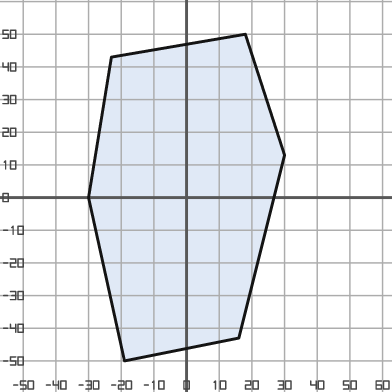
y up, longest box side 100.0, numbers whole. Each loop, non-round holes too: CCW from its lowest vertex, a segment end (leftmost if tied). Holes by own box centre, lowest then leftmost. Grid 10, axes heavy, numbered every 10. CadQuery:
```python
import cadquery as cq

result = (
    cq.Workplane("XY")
    .moveTo(-19.0, -50.0)
    .lineTo(16.0, -43.0)
    .lineTo(30.0, 13.0)
    .lineTo(18.0, 50.0)
    .lineTo(-23.0, 43.0)
    .lineTo(-30.0, 0.0)
    .close()
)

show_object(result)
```